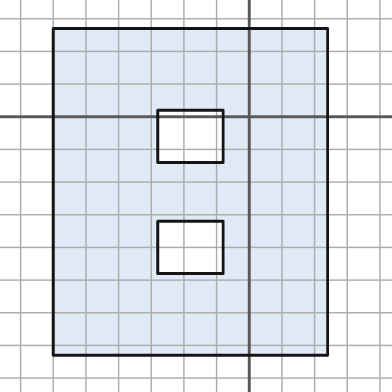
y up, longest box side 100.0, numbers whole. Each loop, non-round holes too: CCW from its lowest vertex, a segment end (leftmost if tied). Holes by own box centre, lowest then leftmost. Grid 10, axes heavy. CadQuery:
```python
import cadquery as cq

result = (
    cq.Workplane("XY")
    .moveTo(-60.0, -73.0)
    .lineTo(24.0, -73.0)
    .lineTo(24.0, 27.0)
    .lineTo(-60.0, 27.0)
    .close()
    .moveTo(-28.0, -48.0)
    .lineTo(-8.0, -48.0)
    .lineTo(-8.0, -32.0)
    .lineTo(-28.0, -32.0)
    .close()
    .moveTo(-28.0, -14.0)
    .lineTo(-8.0, -14.0)
    .lineTo(-8.0, 2.0)
    .lineTo(-28.0, 2.0)
    .close()
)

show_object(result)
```